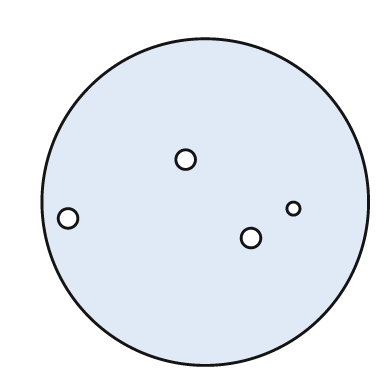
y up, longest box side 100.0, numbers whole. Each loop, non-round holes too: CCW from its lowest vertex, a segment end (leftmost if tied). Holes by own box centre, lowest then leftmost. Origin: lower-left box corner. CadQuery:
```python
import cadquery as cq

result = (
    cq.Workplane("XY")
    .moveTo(50.0, 50.0)
    .circle(50.0)
    .moveTo(64.0, 39.0)
    .circle(3.0)
    .moveTo(8.0, 45.0)
    .circle(3.0)
    .moveTo(77.0, 48.0)
    .circle(2.0)
    .moveTo(44.0, 63.0)
    .circle(3.0)
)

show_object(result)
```